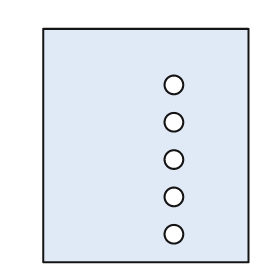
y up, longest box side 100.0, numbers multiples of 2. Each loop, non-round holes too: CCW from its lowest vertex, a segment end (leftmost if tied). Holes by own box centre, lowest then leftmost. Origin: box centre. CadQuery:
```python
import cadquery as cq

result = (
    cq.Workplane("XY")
    .moveTo(-44.0, -50.0)
    .lineTo(44.0, -50.0)
    .lineTo(44.0, 50.0)
    .lineTo(-44.0, 50.0)
    .close()
    .moveTo(12.0, -38.0)
    .circle(4.0)
    .moveTo(12.0, -22.0)
    .circle(4.0)
    .moveTo(12.0, -6.0)
    .circle(4.0)
    .moveTo(12.0, 10.0)
    .circle(4.0)
    .moveTo(12.0, 26.0)
    .circle(4.0)
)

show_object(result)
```